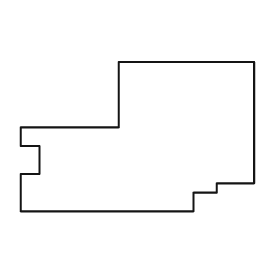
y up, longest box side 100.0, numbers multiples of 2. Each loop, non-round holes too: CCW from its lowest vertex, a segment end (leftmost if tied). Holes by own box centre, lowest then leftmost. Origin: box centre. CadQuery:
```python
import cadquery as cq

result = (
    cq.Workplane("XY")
    .moveTo(-50.0, -32.0)
    .lineTo(24.0, -32.0)
    .lineTo(24.0, -24.0)
    .lineTo(34.0, -24.0)
    .lineTo(34.0, -20.0)
    .lineTo(50.0, -20.0)
    .lineTo(50.0, 32.0)
    .lineTo(-8.0, 32.0)
    .lineTo(-8.0, 4.0)
    .lineTo(-50.0, 4.0)
    .lineTo(-50.0, -4.0)
    .lineTo(-42.0, -4.0)
    .lineTo(-42.0, -16.0)
    .lineTo(-50.0, -16.0)
    .close()
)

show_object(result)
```